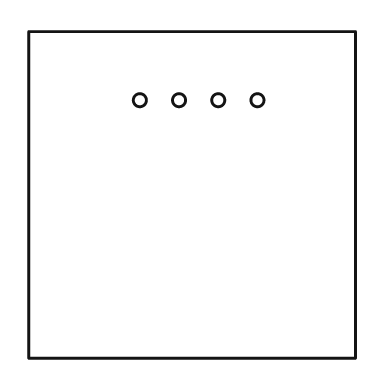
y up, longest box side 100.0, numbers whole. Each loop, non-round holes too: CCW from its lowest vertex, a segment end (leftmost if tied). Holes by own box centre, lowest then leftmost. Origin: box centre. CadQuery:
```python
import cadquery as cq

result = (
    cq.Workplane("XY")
    .moveTo(-50.0, -50.0)
    .lineTo(50.0, -50.0)
    .lineTo(50.0, 50.0)
    .lineTo(-50.0, 50.0)
    .close()
    .moveTo(-16.0, 29.0)
    .circle(2.0)
    .moveTo(-4.0, 29.0)
    .circle(2.0)
    .moveTo(8.0, 29.0)
    .circle(2.0)
    .moveTo(20.0, 29.0)
    .circle(2.0)
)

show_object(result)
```